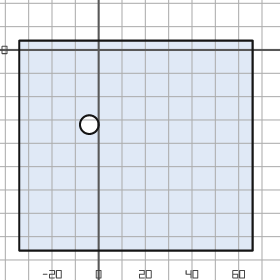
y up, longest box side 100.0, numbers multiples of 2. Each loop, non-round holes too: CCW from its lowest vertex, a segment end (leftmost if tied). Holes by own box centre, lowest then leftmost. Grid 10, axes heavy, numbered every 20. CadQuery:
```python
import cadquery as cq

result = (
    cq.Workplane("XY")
    .moveTo(-34.0, -86.0)
    .lineTo(66.0, -86.0)
    .lineTo(66.0, 4.0)
    .lineTo(-34.0, 4.0)
    .close()
    .moveTo(-4.0, -32.0)
    .circle(4.0)
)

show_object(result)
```